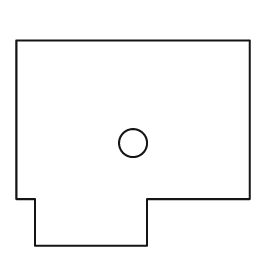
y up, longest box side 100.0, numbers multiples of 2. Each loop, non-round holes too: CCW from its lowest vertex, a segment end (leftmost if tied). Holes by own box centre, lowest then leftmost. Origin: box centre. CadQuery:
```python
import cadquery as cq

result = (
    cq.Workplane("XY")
    .moveTo(-42.0, -44.0)
    .lineTo(6.0, -44.0)
    .lineTo(6.0, -24.0)
    .lineTo(50.0, -24.0)
    .lineTo(50.0, 44.0)
    .lineTo(-50.0, 44.0)
    .lineTo(-50.0, -24.0)
    .lineTo(-42.0, -24.0)
    .close()
    .moveTo(0.0, 0.0)
    .circle(6.0)
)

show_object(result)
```